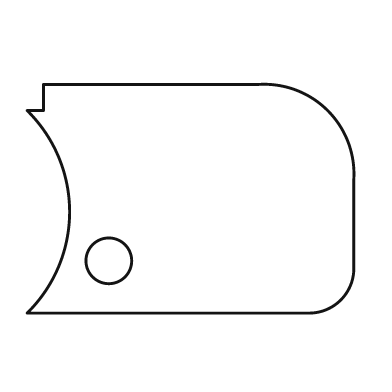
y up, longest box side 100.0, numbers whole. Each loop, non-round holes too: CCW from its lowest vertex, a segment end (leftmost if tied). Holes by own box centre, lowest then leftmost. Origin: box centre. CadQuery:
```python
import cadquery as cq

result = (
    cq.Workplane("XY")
    .moveTo(-50.0, -35.0)
    .lineTo(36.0, -35.0)
    .threePointArc((46.0, -31.0), (50.0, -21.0))
    .lineTo(50.0, 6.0)
    .threePointArc((42.0, 27.0), (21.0, 35.0))
    .lineTo(-45.0, 35.0)
    .lineTo(-45.0, 27.0)
    .lineTo(-50.0, 27.0)
    .threePointArc((-37.0, -4.0), (-50.0, -35.0))
    .close()
    .moveTo(-25.0, -19.0)
    .circle(7.0)
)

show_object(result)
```